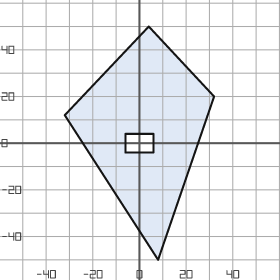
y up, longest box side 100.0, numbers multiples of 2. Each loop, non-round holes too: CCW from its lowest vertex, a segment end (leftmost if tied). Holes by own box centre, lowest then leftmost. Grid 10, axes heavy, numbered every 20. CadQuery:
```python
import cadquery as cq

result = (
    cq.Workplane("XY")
    .moveTo(8.0, -50.0)
    .lineTo(32.0, 20.0)
    .lineTo(4.0, 50.0)
    .lineTo(-32.0, 12.0)
    .close()
    .moveTo(-6.0, -4.0)
    .lineTo(6.0, -4.0)
    .lineTo(6.0, 4.0)
    .lineTo(-6.0, 4.0)
    .close()
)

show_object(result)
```